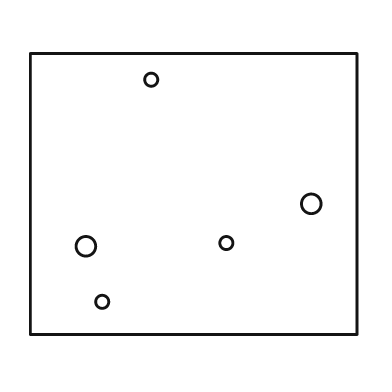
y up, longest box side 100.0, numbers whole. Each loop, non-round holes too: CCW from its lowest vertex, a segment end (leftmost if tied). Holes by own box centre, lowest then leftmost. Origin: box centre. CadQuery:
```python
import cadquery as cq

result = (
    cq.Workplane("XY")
    .moveTo(-50.0, -43.0)
    .lineTo(50.0, -43.0)
    .lineTo(50.0, 43.0)
    .lineTo(-50.0, 43.0)
    .close()
    .moveTo(-28.0, -33.0)
    .circle(2.0)
    .moveTo(-33.0, -16.0)
    .circle(3.0)
    .moveTo(10.0, -15.0)
    .circle(2.0)
    .moveTo(36.0, -3.0)
    .circle(3.0)
    .moveTo(-13.0, 35.0)
    .circle(2.0)
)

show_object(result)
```